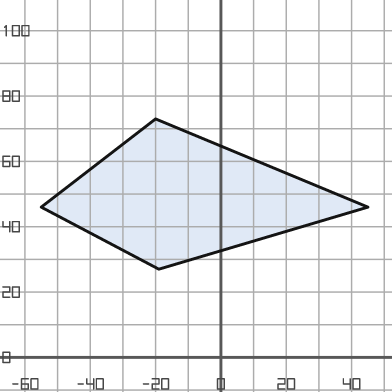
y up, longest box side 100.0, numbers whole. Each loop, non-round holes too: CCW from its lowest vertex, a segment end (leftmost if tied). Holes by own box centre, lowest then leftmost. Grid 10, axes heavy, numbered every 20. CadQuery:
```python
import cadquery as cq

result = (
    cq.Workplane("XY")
    .moveTo(-19.0, 27.0)
    .lineTo(45.0, 46.0)
    .lineTo(-20.0, 73.0)
    .lineTo(-55.0, 46.0)
    .close()
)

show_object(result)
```